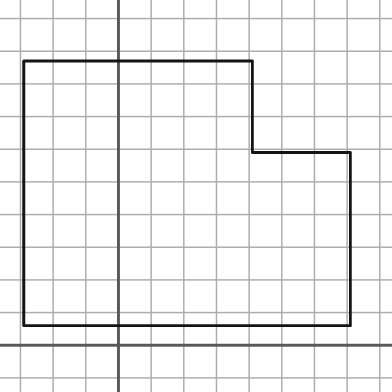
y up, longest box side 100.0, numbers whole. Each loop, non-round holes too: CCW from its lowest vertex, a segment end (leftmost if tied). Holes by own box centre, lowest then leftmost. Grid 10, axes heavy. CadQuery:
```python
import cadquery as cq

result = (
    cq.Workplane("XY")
    .moveTo(-29.0, 6.0)
    .lineTo(71.0, 6.0)
    .lineTo(71.0, 59.0)
    .lineTo(41.0, 59.0)
    .lineTo(41.0, 87.0)
    .lineTo(-29.0, 87.0)
    .close()
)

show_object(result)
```